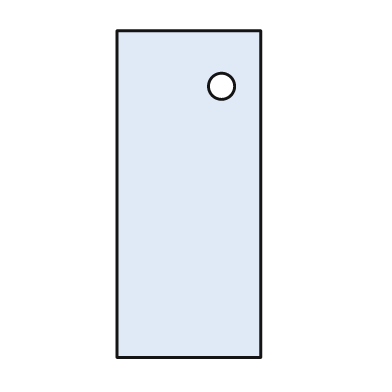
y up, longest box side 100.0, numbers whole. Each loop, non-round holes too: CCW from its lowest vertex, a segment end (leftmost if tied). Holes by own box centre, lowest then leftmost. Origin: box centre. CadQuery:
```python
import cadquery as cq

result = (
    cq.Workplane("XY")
    .moveTo(-22.0, -50.0)
    .lineTo(22.0, -50.0)
    .lineTo(22.0, 50.0)
    .lineTo(-22.0, 50.0)
    .close()
    .moveTo(10.0, 33.0)
    .circle(4.0)
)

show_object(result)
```